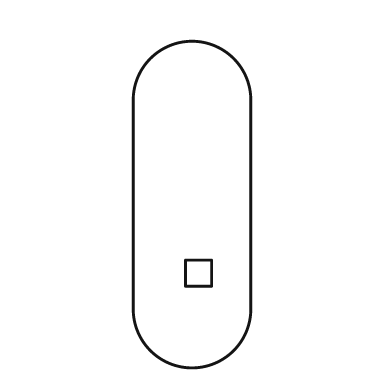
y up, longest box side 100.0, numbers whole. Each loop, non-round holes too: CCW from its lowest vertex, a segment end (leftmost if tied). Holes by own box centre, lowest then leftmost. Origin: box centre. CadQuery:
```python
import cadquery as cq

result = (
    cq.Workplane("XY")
    .moveTo(-18.0, -32.0)
    .threePointArc((0.0, -50.0), (18.0, -32.0))
    .lineTo(18.0, 32.0)
    .threePointArc((0.0, 50.0), (-18.0, 32.0))
    .close()
    .moveTo(-2.0, -25.0)
    .lineTo(6.0, -25.0)
    .lineTo(6.0, -17.0)
    .lineTo(-2.0, -17.0)
    .close()
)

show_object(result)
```